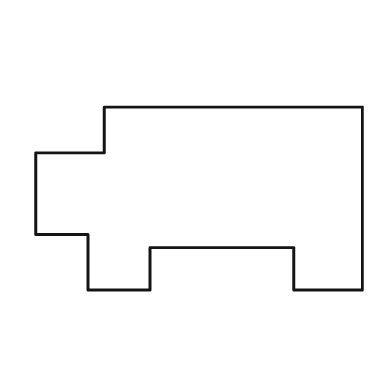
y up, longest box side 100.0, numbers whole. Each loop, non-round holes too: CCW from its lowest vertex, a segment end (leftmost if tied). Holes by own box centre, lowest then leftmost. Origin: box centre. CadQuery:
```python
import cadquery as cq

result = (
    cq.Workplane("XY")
    .moveTo(-34.0, -28.0)
    .lineTo(-15.0, -28.0)
    .lineTo(-15.0, -15.0)
    .lineTo(29.0, -15.0)
    .lineTo(29.0, -28.0)
    .lineTo(50.0, -28.0)
    .lineTo(50.0, 28.0)
    .lineTo(-29.0, 28.0)
    .lineTo(-29.0, 14.0)
    .lineTo(-50.0, 14.0)
    .lineTo(-50.0, -11.0)
    .lineTo(-34.0, -11.0)
    .close()
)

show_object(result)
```